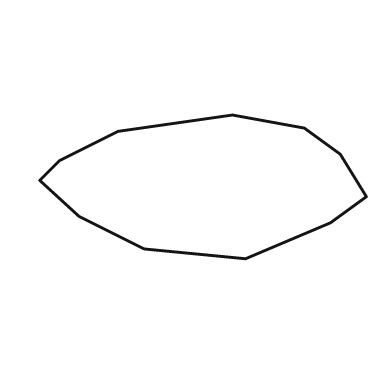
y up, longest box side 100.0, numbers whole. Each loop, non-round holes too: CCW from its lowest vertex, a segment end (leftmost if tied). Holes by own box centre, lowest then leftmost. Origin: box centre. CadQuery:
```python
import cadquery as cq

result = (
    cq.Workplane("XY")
    .moveTo(13.0, -22.0)
    .lineTo(39.0, -11.0)
    .lineTo(50.0, -3.0)
    .lineTo(42.0, 10.0)
    .lineTo(31.0, 18.0)
    .lineTo(9.0, 22.0)
    .lineTo(-26.0, 17.0)
    .lineTo(-44.0, 8.0)
    .lineTo(-50.0, 2.0)
    .lineTo(-38.0, -9.0)
    .lineTo(-18.0, -19.0)
    .close()
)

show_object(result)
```